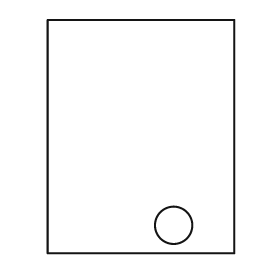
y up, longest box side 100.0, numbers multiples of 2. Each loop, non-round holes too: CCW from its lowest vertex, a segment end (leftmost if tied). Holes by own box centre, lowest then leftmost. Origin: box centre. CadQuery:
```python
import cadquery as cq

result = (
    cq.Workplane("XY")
    .moveTo(-40.0, -50.0)
    .lineTo(40.0, -50.0)
    .lineTo(40.0, 50.0)
    .lineTo(-40.0, 50.0)
    .close()
    .moveTo(14.0, -38.0)
    .circle(8.0)
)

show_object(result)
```